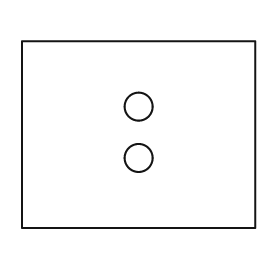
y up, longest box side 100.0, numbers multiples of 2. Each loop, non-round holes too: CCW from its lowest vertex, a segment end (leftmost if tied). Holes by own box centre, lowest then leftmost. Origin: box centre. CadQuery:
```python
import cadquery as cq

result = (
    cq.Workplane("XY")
    .moveTo(-50.0, -40.0)
    .lineTo(50.0, -40.0)
    .lineTo(50.0, 40.0)
    .lineTo(-50.0, 40.0)
    .close()
    .moveTo(0.0, -10.0)
    .circle(6.0)
    .moveTo(0.0, 12.0)
    .circle(6.0)
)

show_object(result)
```